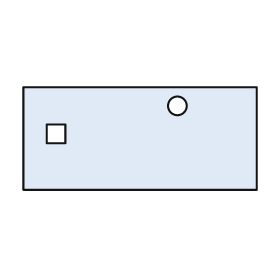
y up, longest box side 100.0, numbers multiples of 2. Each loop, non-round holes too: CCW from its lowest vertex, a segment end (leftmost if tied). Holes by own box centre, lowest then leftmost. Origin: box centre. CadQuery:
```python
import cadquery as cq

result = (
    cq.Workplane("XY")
    .moveTo(-50.0, -22.0)
    .lineTo(50.0, -22.0)
    .lineTo(50.0, 22.0)
    .lineTo(-50.0, 22.0)
    .close()
    .moveTo(-40.0, -2.0)
    .lineTo(-32.0, -2.0)
    .lineTo(-32.0, 6.0)
    .lineTo(-40.0, 6.0)
    .close()
    .moveTo(16.0, 14.0)
    .circle(4.0)
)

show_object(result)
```